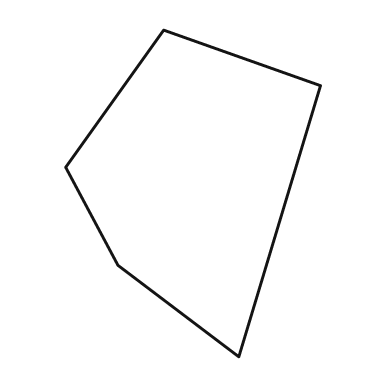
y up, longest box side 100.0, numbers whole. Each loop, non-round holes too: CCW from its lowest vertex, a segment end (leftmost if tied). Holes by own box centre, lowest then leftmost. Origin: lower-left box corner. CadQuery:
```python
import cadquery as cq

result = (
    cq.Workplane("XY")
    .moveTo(53.0, 0.0)
    .lineTo(78.0, 83.0)
    .lineTo(30.0, 100.0)
    .lineTo(0.0, 58.0)
    .lineTo(16.0, 28.0)
    .close()
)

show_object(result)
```